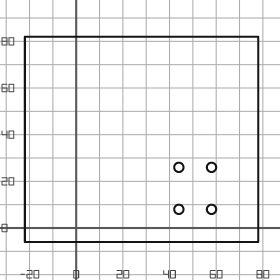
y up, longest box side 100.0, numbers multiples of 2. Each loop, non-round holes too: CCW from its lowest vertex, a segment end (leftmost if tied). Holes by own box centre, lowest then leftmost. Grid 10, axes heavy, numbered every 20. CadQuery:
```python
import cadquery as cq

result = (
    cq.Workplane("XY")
    .moveTo(-22.0, -6.0)
    .lineTo(78.0, -6.0)
    .lineTo(78.0, 82.0)
    .lineTo(-22.0, 82.0)
    .close()
    .moveTo(44.0, 8.0)
    .circle(2.0)
    .moveTo(58.0, 8.0)
    .circle(2.0)
    .moveTo(44.0, 26.0)
    .circle(2.0)
    .moveTo(58.0, 26.0)
    .circle(2.0)
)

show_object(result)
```